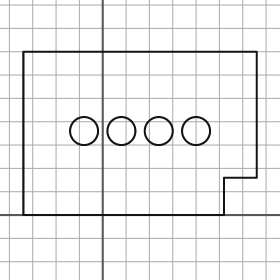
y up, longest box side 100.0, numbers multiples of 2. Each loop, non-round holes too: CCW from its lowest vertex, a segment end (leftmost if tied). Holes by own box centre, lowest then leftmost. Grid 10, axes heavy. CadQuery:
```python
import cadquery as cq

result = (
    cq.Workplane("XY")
    .moveTo(-34.0, 0.0)
    .lineTo(52.0, 0.0)
    .lineTo(52.0, 16.0)
    .lineTo(66.0, 16.0)
    .lineTo(66.0, 70.0)
    .lineTo(-34.0, 70.0)
    .close()
    .moveTo(-8.0, 36.0)
    .circle(6.0)
    .moveTo(8.0, 36.0)
    .circle(6.0)
    .moveTo(24.0, 36.0)
    .circle(6.0)
    .moveTo(40.0, 36.0)
    .circle(6.0)
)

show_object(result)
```